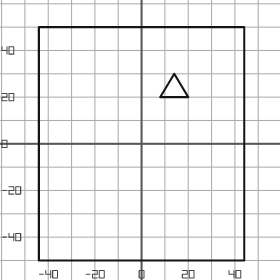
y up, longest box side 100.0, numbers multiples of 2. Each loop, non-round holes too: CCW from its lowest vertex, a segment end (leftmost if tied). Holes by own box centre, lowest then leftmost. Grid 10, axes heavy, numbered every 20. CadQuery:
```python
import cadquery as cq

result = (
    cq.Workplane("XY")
    .moveTo(-44.0, -50.0)
    .lineTo(44.0, -50.0)
    .lineTo(44.0, 50.0)
    .lineTo(-44.0, 50.0)
    .close()
    .moveTo(8.0, 20.0)
    .lineTo(20.0, 20.0)
    .lineTo(14.0, 30.0)
    .close()
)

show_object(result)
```